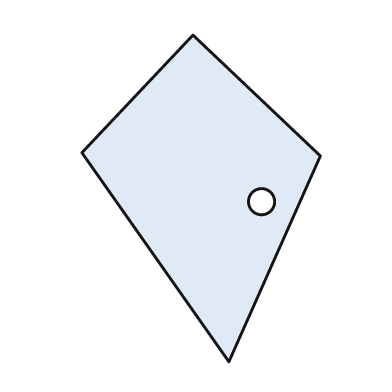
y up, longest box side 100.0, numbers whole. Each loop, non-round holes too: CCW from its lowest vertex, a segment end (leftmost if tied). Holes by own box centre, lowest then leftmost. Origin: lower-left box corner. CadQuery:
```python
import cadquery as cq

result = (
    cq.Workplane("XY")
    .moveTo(45.0, 0.0)
    .lineTo(73.0, 63.0)
    .lineTo(34.0, 100.0)
    .lineTo(0.0, 64.0)
    .close()
    .moveTo(55.0, 49.0)
    .circle(4.0)
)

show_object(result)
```